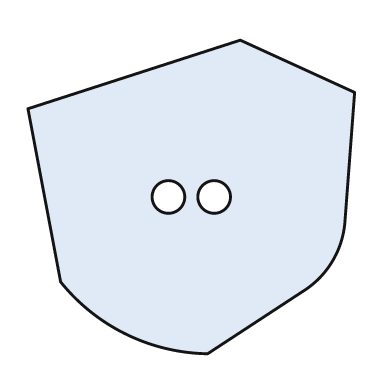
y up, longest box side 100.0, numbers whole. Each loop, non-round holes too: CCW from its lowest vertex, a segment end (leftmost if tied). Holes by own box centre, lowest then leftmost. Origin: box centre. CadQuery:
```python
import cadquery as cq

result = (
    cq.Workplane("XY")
    .moveTo(5.0, -48.0)
    .lineTo(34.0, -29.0)
    .threePointArc((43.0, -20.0), (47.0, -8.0))
    .lineTo(50.0, 32.0)
    .lineTo(15.0, 48.0)
    .lineTo(-50.0, 27.0)
    .lineTo(-40.0, -26.0)
    .threePointArc((-20.0, -42.0), (5.0, -48.0))
    .close()
    .moveTo(-7.0, 0.0)
    .circle(5.0)
    .moveTo(7.0, 0.0)
    .circle(5.0)
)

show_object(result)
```